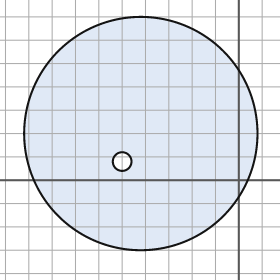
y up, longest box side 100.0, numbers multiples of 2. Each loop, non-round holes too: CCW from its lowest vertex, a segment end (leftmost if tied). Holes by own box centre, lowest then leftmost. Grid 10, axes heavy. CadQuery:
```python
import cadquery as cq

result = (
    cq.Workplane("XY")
    .moveTo(-42.0, 20.0)
    .circle(50.0)
    .moveTo(-50.0, 8.0)
    .circle(4.0)
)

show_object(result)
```